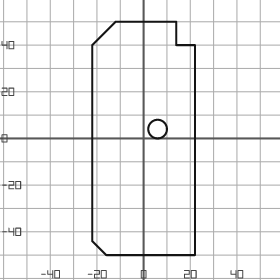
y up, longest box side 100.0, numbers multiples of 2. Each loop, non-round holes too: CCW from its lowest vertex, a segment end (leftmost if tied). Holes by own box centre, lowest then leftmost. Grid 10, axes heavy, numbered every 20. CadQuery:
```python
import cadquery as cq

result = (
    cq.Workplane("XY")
    .moveTo(-16.0, -50.0)
    .lineTo(22.0, -50.0)
    .lineTo(22.0, 40.0)
    .lineTo(14.0, 40.0)
    .lineTo(14.0, 50.0)
    .lineTo(-12.0, 50.0)
    .lineTo(-22.0, 40.0)
    .lineTo(-22.0, -44.0)
    .close()
    .moveTo(6.0, 4.0)
    .circle(4.0)
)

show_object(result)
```